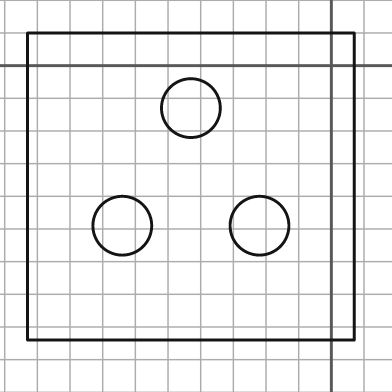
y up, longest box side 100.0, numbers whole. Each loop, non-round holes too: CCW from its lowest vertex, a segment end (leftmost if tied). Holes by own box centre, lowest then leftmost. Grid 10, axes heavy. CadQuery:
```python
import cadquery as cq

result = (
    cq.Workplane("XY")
    .moveTo(-93.0, -84.0)
    .lineTo(7.0, -84.0)
    .lineTo(7.0, 10.0)
    .lineTo(-93.0, 10.0)
    .close()
    .moveTo(-64.0, -49.0)
    .circle(9.0)
    .moveTo(-22.0, -49.0)
    .circle(9.0)
    .moveTo(-43.0, -13.0)
    .circle(9.0)
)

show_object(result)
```